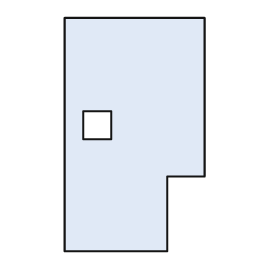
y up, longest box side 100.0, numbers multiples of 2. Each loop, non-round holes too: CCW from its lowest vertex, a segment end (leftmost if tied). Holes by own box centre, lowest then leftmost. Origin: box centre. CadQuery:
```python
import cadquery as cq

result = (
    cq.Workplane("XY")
    .moveTo(-30.0, -50.0)
    .lineTo(14.0, -50.0)
    .lineTo(14.0, -18.0)
    .lineTo(30.0, -18.0)
    .lineTo(30.0, 50.0)
    .lineTo(-30.0, 50.0)
    .close()
    .moveTo(-22.0, -2.0)
    .lineTo(-10.0, -2.0)
    .lineTo(-10.0, 10.0)
    .lineTo(-22.0, 10.0)
    .close()
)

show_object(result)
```